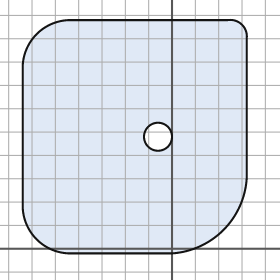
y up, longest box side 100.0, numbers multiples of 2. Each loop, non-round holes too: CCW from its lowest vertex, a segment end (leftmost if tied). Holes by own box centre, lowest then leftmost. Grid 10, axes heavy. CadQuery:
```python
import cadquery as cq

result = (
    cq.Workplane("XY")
    .moveTo(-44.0, -2.0)
    .lineTo(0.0, -2.0)
    .threePointArc((22.0, 8.0), (32.0, 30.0))
    .lineTo(32.0, 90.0)
    .threePointArc((30.0, 96.0), (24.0, 98.0))
    .lineTo(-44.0, 98.0)
    .threePointArc((-58.0, 92.0), (-64.0, 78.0))
    .lineTo(-64.0, 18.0)
    .threePointArc((-58.0, 4.0), (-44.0, -2.0))
    .close()
    .moveTo(-6.0, 48.0)
    .circle(6.0)
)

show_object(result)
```